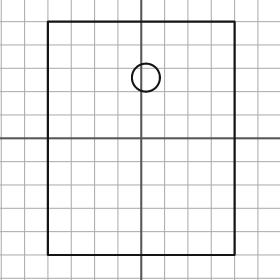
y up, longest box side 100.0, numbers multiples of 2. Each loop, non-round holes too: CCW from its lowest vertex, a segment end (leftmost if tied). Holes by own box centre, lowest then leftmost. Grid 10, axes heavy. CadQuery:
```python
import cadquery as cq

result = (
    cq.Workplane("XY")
    .moveTo(-40.0, -50.0)
    .lineTo(40.0, -50.0)
    .lineTo(40.0, 50.0)
    .lineTo(-40.0, 50.0)
    .close()
    .moveTo(2.0, 26.0)
    .circle(6.0)
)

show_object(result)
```